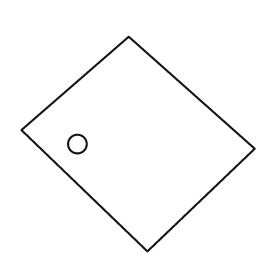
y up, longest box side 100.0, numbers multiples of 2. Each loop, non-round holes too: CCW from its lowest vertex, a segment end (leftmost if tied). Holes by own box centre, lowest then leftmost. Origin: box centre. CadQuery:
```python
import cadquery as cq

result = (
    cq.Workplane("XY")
    .moveTo(4.0, -46.0)
    .lineTo(50.0, -2.0)
    .lineTo(-4.0, 46.0)
    .lineTo(-50.0, 6.0)
    .close()
    .moveTo(-26.0, 0.0)
    .circle(4.0)
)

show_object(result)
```